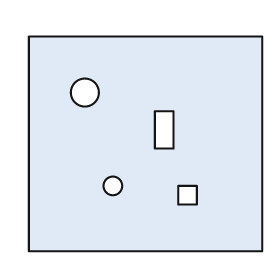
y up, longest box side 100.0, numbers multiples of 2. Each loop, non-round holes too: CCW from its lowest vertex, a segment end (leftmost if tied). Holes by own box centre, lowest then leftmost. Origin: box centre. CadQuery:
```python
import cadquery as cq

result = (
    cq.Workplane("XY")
    .moveTo(-50.0, -46.0)
    .lineTo(50.0, -46.0)
    .lineTo(50.0, 46.0)
    .lineTo(-50.0, 46.0)
    .close()
    .moveTo(14.0, -26.0)
    .lineTo(22.0, -26.0)
    .lineTo(22.0, -18.0)
    .lineTo(14.0, -18.0)
    .close()
    .moveTo(-14.0, -18.0)
    .circle(4.0)
    .moveTo(4.0, -2.0)
    .lineTo(12.0, -2.0)
    .lineTo(12.0, 14.0)
    .lineTo(4.0, 14.0)
    .close()
    .moveTo(-26.0, 22.0)
    .circle(6.0)
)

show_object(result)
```